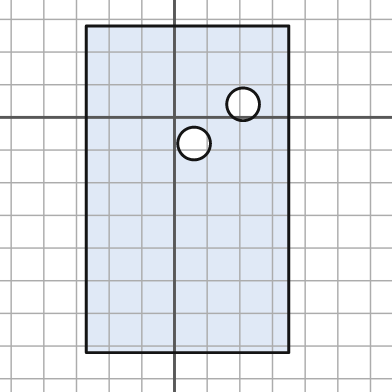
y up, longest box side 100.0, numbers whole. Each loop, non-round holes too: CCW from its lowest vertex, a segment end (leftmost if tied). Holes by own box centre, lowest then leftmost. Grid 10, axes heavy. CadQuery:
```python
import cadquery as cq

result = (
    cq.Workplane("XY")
    .moveTo(-27.0, -72.0)
    .lineTo(35.0, -72.0)
    .lineTo(35.0, 28.0)
    .lineTo(-27.0, 28.0)
    .close()
    .moveTo(6.0, -8.0)
    .circle(5.0)
    .moveTo(21.0, 4.0)
    .circle(5.0)
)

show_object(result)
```